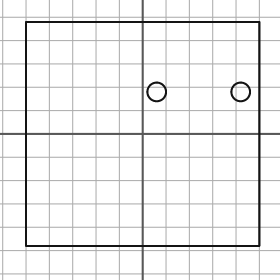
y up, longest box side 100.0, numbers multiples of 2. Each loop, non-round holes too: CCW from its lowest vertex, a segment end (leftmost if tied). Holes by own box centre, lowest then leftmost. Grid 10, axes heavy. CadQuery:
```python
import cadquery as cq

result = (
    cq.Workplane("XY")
    .moveTo(-50.0, -48.0)
    .lineTo(50.0, -48.0)
    .lineTo(50.0, 48.0)
    .lineTo(-50.0, 48.0)
    .close()
    .moveTo(6.0, 18.0)
    .circle(4.0)
    .moveTo(42.0, 18.0)
    .circle(4.0)
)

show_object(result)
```